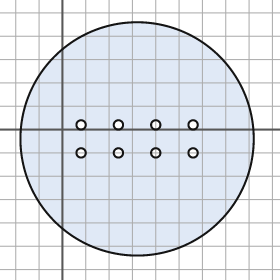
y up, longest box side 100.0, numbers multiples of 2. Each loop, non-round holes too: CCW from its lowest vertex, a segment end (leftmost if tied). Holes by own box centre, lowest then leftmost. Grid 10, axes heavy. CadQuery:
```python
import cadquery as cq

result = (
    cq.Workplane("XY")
    .moveTo(32.0, -4.0)
    .circle(50.0)
    .moveTo(8.0, -10.0)
    .circle(2.0)
    .moveTo(24.0, -10.0)
    .circle(2.0)
    .moveTo(40.0, -10.0)
    .circle(2.0)
    .moveTo(56.0, -10.0)
    .circle(2.0)
    .moveTo(8.0, 2.0)
    .circle(2.0)
    .moveTo(24.0, 2.0)
    .circle(2.0)
    .moveTo(40.0, 2.0)
    .circle(2.0)
    .moveTo(56.0, 2.0)
    .circle(2.0)
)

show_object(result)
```